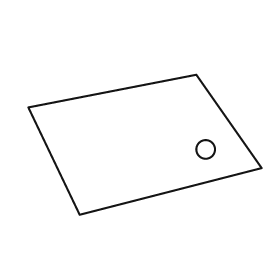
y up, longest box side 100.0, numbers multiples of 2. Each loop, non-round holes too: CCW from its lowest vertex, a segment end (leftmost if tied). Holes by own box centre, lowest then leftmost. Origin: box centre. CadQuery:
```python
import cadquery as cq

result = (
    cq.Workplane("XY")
    .moveTo(-28.0, -30.0)
    .lineTo(50.0, -10.0)
    .lineTo(22.0, 30.0)
    .lineTo(-50.0, 16.0)
    .close()
    .moveTo(26.0, -2.0)
    .circle(4.0)
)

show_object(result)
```